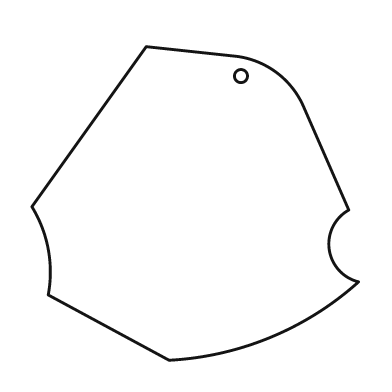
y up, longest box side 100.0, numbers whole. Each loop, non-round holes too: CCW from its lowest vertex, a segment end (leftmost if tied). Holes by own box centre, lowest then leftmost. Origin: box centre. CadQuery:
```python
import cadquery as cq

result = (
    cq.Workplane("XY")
    .moveTo(-8.0, -48.0)
    .threePointArc((23.0, -41.0), (50.0, -24.0))
    .threePointArc((41.0, -14.0), (47.0, -2.0))
    .lineTo(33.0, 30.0)
    .threePointArc((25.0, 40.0), (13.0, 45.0))
    .lineTo(-15.0, 48.0)
    .lineTo(-50.0, -1.0)
    .threePointArc((-45.0, -14.0), (-45.0, -28.0))
    .close()
    .moveTo(14.0, 39.0)
    .circle(2.0)
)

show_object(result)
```